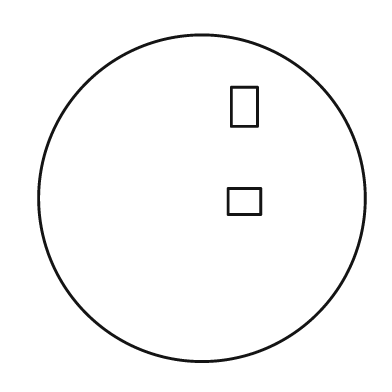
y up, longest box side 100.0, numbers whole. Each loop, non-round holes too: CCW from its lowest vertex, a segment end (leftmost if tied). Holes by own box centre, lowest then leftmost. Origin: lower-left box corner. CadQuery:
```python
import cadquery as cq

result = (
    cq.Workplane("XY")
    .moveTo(50.0, 50.0)
    .circle(50.0)
    .moveTo(58.0, 45.0)
    .lineTo(68.0, 45.0)
    .lineTo(68.0, 53.0)
    .lineTo(58.0, 53.0)
    .close()
    .moveTo(59.0, 72.0)
    .lineTo(67.0, 72.0)
    .lineTo(67.0, 84.0)
    .lineTo(59.0, 84.0)
    .close()
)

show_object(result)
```